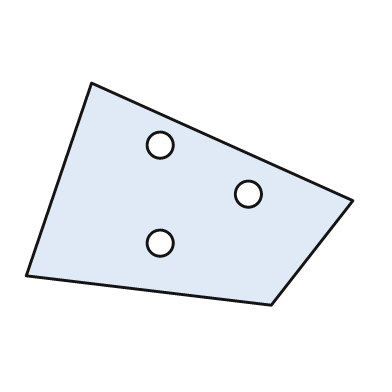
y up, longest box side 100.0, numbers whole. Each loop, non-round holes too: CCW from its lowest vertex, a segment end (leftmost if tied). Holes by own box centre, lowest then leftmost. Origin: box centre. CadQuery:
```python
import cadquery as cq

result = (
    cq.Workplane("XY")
    .moveTo(25.0, -34.0)
    .lineTo(50.0, -2.0)
    .lineTo(-30.0, 34.0)
    .lineTo(-50.0, -25.0)
    .close()
    .moveTo(-9.0, -15.0)
    .circle(4.0)
    .moveTo(18.0, 0.0)
    .circle(4.0)
    .moveTo(-9.0, 15.0)
    .circle(4.0)
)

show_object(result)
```